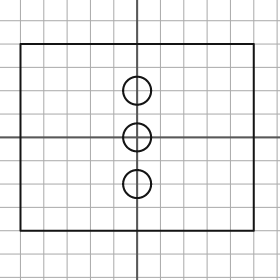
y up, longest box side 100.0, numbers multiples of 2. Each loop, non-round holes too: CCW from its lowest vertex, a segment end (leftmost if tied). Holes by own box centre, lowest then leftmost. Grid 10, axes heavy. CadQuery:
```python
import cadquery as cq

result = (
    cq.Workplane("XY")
    .moveTo(-50.0, -40.0)
    .lineTo(50.0, -40.0)
    .lineTo(50.0, 40.0)
    .lineTo(-50.0, 40.0)
    .close()
    .moveTo(0.0, -20.0)
    .circle(6.0)
    .moveTo(0.0, 0.0)
    .circle(6.0)
    .moveTo(0.0, 20.0)
    .circle(6.0)
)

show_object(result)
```